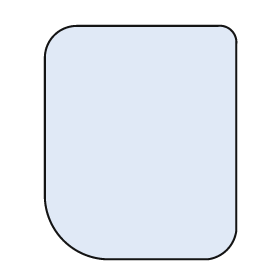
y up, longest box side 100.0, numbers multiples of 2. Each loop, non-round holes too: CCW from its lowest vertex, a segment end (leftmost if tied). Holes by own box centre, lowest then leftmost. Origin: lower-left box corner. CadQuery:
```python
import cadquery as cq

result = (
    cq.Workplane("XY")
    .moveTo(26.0, 0.0)
    .lineTo(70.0, 0.0)
    .threePointArc((78.0, 4.0), (82.0, 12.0))
    .lineTo(82.0, 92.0)
    .threePointArc((80.0, 98.0), (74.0, 100.0))
    .lineTo(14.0, 100.0)
    .threePointArc((4.0, 96.0), (0.0, 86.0))
    .lineTo(0.0, 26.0)
    .threePointArc((8.0, 8.0), (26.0, 0.0))
    .close()
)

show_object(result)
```